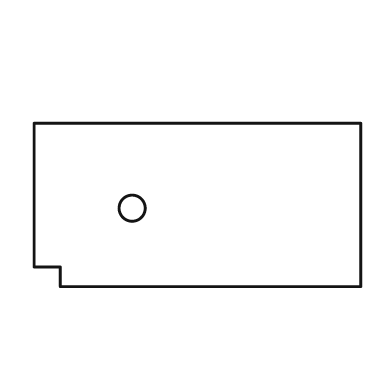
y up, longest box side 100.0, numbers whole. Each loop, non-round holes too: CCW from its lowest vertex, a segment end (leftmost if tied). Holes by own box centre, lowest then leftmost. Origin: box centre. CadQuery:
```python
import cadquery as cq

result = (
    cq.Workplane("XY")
    .moveTo(-42.0, -25.0)
    .lineTo(50.0, -25.0)
    .lineTo(50.0, 25.0)
    .lineTo(-50.0, 25.0)
    .lineTo(-50.0, -19.0)
    .lineTo(-42.0, -19.0)
    .close()
    .moveTo(-20.0, -1.0)
    .circle(4.0)
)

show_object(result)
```